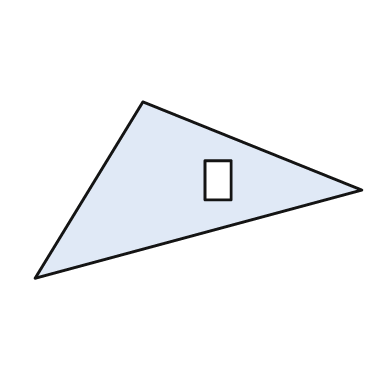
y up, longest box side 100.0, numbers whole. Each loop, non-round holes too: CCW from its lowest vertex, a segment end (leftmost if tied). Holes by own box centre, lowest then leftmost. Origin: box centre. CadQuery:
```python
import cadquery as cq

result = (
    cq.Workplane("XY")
    .moveTo(-50.0, -27.0)
    .lineTo(50.0, 0.0)
    .lineTo(-17.0, 27.0)
    .close()
    .moveTo(2.0, -3.0)
    .lineTo(10.0, -3.0)
    .lineTo(10.0, 9.0)
    .lineTo(2.0, 9.0)
    .close()
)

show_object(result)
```